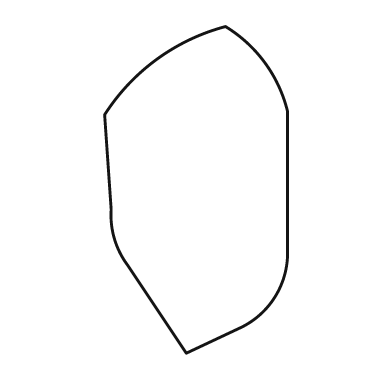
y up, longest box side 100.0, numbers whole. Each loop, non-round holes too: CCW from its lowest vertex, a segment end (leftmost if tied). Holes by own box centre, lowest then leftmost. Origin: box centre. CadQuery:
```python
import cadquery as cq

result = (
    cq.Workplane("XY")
    .moveTo(-3.0, -50.0)
    .lineTo(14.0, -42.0)
    .threePointArc((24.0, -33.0), (28.0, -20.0))
    .lineTo(28.0, 24.0)
    .threePointArc((21.0, 39.0), (9.0, 50.0))
    .threePointArc((-12.0, 40.0), (-28.0, 23.0))
    .lineTo(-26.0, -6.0)
    .threePointArc((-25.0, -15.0), (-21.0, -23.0))
    .close()
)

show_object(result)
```